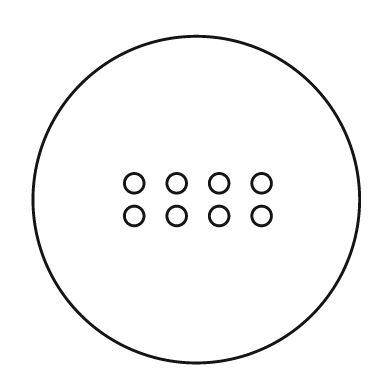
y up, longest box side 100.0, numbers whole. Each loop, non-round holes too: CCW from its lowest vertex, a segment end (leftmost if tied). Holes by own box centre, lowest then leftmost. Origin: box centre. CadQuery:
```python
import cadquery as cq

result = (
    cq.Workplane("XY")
    .moveTo(0.0, 0.0)
    .circle(50.0)
    .moveTo(-19.0, -5.0)
    .circle(3.0)
    .moveTo(-6.0, -5.0)
    .circle(3.0)
    .moveTo(7.0, -5.0)
    .circle(3.0)
    .moveTo(20.0, -5.0)
    .circle(3.0)
    .moveTo(-19.0, 5.0)
    .circle(3.0)
    .moveTo(-6.0, 5.0)
    .circle(3.0)
    .moveTo(7.0, 5.0)
    .circle(3.0)
    .moveTo(20.0, 5.0)
    .circle(3.0)
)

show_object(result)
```